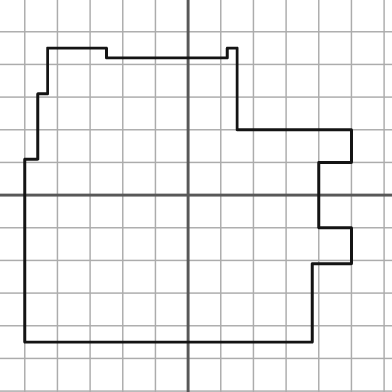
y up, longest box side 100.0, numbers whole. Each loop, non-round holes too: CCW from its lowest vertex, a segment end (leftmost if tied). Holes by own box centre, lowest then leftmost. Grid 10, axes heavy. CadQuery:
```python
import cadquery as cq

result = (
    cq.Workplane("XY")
    .moveTo(-50.0, -45.0)
    .lineTo(38.0, -45.0)
    .lineTo(38.0, -21.0)
    .lineTo(50.0, -21.0)
    .lineTo(50.0, -10.0)
    .lineTo(40.0, -10.0)
    .lineTo(40.0, 10.0)
    .lineTo(50.0, 10.0)
    .lineTo(50.0, 20.0)
    .lineTo(15.0, 20.0)
    .lineTo(15.0, 45.0)
    .lineTo(12.0, 45.0)
    .lineTo(12.0, 42.0)
    .lineTo(-25.0, 42.0)
    .lineTo(-25.0, 45.0)
    .lineTo(-43.0, 45.0)
    .lineTo(-43.0, 31.0)
    .lineTo(-46.0, 31.0)
    .lineTo(-46.0, 11.0)
    .lineTo(-50.0, 11.0)
    .close()
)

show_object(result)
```